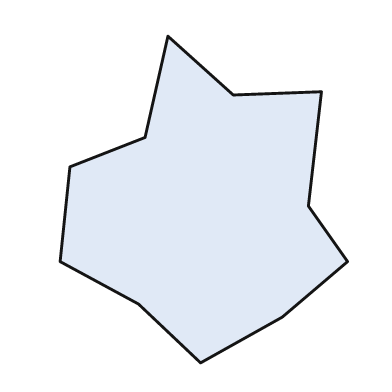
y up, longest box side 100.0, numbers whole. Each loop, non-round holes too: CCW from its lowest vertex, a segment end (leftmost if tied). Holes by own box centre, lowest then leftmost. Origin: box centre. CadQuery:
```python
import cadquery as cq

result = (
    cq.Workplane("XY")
    .moveTo(-1.0, -50.0)
    .lineTo(24.0, -36.0)
    .lineTo(44.0, -19.0)
    .lineTo(32.0, -2.0)
    .lineTo(36.0, 33.0)
    .lineTo(9.0, 32.0)
    .lineTo(-11.0, 50.0)
    .lineTo(-18.0, 19.0)
    .lineTo(-41.0, 10.0)
    .lineTo(-44.0, -19.0)
    .lineTo(-20.0, -32.0)
    .close()
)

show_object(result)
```